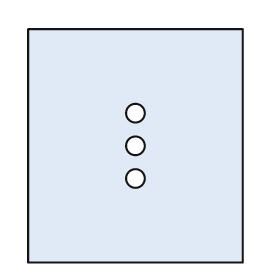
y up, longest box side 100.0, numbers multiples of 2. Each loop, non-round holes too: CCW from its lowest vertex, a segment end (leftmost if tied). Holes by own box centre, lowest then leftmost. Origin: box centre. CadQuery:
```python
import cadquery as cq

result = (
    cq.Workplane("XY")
    .moveTo(-46.0, -50.0)
    .lineTo(46.0, -50.0)
    .lineTo(46.0, 50.0)
    .lineTo(-46.0, 50.0)
    .close()
    .moveTo(0.0, -14.0)
    .circle(4.0)
    .moveTo(0.0, 0.0)
    .circle(4.0)
    .moveTo(0.0, 14.0)
    .circle(4.0)
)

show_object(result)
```